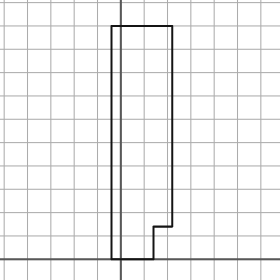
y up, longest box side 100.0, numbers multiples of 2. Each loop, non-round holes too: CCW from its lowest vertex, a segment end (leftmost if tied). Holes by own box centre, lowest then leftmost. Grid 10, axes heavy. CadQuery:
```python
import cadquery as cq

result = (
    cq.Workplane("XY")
    .moveTo(-4.0, 0.0)
    .lineTo(14.0, 0.0)
    .lineTo(14.0, 14.0)
    .lineTo(22.0, 14.0)
    .lineTo(22.0, 100.0)
    .lineTo(-4.0, 100.0)
    .close()
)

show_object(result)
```